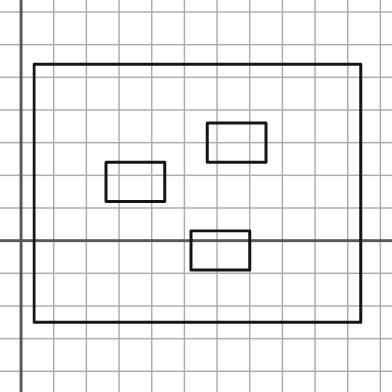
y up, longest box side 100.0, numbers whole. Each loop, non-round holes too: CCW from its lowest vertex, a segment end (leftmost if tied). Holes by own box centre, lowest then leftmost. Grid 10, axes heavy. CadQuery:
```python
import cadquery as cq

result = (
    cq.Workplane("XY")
    .moveTo(4.0, -25.0)
    .lineTo(104.0, -25.0)
    .lineTo(104.0, 54.0)
    .lineTo(4.0, 54.0)
    .close()
    .moveTo(52.0, -9.0)
    .lineTo(70.0, -9.0)
    .lineTo(70.0, 3.0)
    .lineTo(52.0, 3.0)
    .close()
    .moveTo(26.0, 12.0)
    .lineTo(44.0, 12.0)
    .lineTo(44.0, 24.0)
    .lineTo(26.0, 24.0)
    .close()
    .moveTo(57.0, 24.0)
    .lineTo(75.0, 24.0)
    .lineTo(75.0, 36.0)
    .lineTo(57.0, 36.0)
    .close()
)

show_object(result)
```